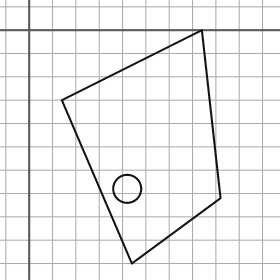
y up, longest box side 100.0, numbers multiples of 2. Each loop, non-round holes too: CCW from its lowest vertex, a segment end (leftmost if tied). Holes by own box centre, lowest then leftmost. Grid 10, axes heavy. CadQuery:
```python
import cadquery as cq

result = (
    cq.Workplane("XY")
    .moveTo(44.0, -100.0)
    .lineTo(82.0, -72.0)
    .lineTo(74.0, 0.0)
    .lineTo(14.0, -30.0)
    .close()
    .moveTo(42.0, -68.0)
    .circle(6.0)
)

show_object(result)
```